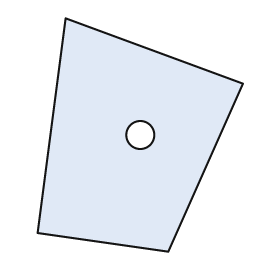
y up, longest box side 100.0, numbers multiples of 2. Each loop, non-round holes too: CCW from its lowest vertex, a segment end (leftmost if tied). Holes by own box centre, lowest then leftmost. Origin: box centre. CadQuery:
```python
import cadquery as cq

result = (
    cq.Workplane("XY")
    .moveTo(12.0, -50.0)
    .lineTo(44.0, 22.0)
    .lineTo(-32.0, 50.0)
    .lineTo(-44.0, -42.0)
    .close()
    .moveTo(0.0, 0.0)
    .circle(6.0)
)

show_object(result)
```